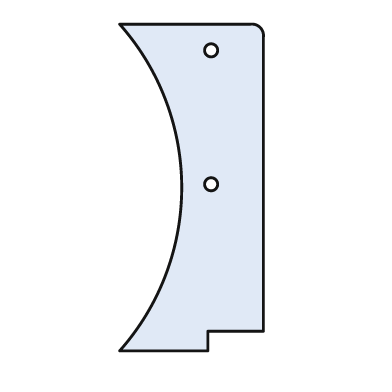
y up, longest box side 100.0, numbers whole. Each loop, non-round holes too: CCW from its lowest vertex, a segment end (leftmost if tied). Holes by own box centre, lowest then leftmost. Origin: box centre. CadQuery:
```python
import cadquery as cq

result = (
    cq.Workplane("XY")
    .moveTo(-22.0, -50.0)
    .lineTo(5.0, -50.0)
    .lineTo(5.0, -44.0)
    .lineTo(22.0, -44.0)
    .lineTo(22.0, 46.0)
    .threePointArc((21.0, 49.0), (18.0, 50.0))
    .lineTo(-22.0, 50.0)
    .threePointArc((-3.0, 0.0), (-22.0, -50.0))
    .close()
    .moveTo(6.0, 1.0)
    .circle(2.0)
    .moveTo(6.0, 42.0)
    .circle(2.0)
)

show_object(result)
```